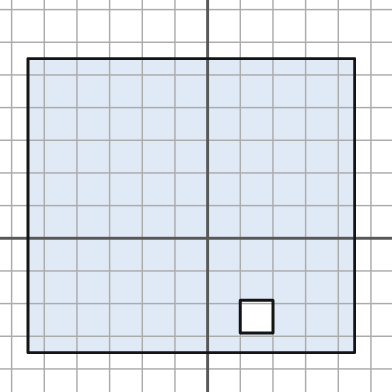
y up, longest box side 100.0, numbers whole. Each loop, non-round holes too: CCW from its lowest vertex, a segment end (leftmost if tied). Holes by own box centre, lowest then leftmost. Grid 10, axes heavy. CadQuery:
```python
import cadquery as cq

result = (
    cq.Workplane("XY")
    .moveTo(-55.0, -35.0)
    .lineTo(45.0, -35.0)
    .lineTo(45.0, 55.0)
    .lineTo(-55.0, 55.0)
    .close()
    .moveTo(10.0, -29.0)
    .lineTo(20.0, -29.0)
    .lineTo(20.0, -19.0)
    .lineTo(10.0, -19.0)
    .close()
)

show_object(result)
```